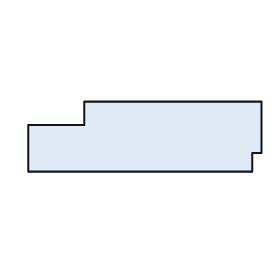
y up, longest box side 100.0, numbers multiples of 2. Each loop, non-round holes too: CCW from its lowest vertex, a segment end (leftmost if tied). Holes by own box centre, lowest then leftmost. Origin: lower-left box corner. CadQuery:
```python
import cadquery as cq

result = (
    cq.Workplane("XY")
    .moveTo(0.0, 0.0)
    .lineTo(96.0, 0.0)
    .lineTo(96.0, 8.0)
    .lineTo(100.0, 8.0)
    .lineTo(100.0, 30.0)
    .lineTo(24.0, 30.0)
    .lineTo(24.0, 20.0)
    .lineTo(0.0, 20.0)
    .close()
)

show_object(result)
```